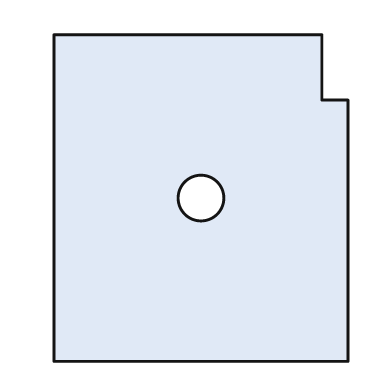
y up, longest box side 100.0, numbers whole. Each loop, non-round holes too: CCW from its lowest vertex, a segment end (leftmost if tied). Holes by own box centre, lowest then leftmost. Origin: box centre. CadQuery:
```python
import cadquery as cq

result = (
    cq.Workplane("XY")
    .moveTo(-45.0, -50.0)
    .lineTo(45.0, -50.0)
    .lineTo(45.0, 30.0)
    .lineTo(37.0, 30.0)
    .lineTo(37.0, 50.0)
    .lineTo(-45.0, 50.0)
    .close()
    .moveTo(0.0, 0.0)
    .circle(7.0)
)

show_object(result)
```